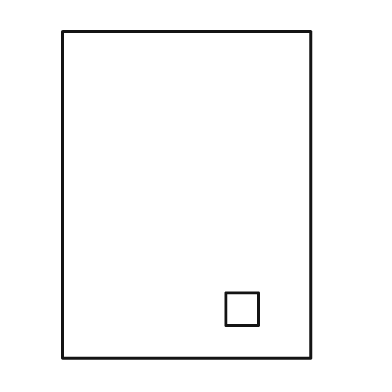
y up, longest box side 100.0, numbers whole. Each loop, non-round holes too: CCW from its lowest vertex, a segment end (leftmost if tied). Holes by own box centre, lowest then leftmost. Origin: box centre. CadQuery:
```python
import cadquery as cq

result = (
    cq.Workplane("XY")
    .moveTo(-38.0, -50.0)
    .lineTo(38.0, -50.0)
    .lineTo(38.0, 50.0)
    .lineTo(-38.0, 50.0)
    .close()
    .moveTo(12.0, -40.0)
    .lineTo(22.0, -40.0)
    .lineTo(22.0, -30.0)
    .lineTo(12.0, -30.0)
    .close()
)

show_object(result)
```